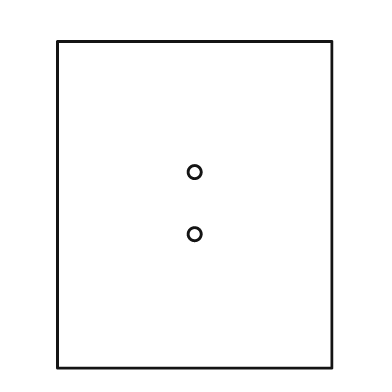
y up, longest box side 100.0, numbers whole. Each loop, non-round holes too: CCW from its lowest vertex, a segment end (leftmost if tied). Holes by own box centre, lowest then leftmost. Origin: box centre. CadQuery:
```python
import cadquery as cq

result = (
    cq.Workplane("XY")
    .moveTo(-42.0, -50.0)
    .lineTo(42.0, -50.0)
    .lineTo(42.0, 50.0)
    .lineTo(-42.0, 50.0)
    .close()
    .moveTo(0.0, -9.0)
    .circle(2.0)
    .moveTo(0.0, 10.0)
    .circle(2.0)
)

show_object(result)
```